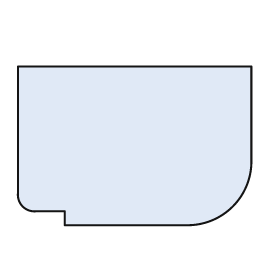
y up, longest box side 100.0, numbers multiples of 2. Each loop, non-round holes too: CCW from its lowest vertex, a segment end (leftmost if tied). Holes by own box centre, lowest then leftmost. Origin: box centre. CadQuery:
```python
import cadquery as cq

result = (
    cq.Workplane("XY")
    .moveTo(-30.0, -34.0)
    .lineTo(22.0, -34.0)
    .threePointArc((42.0, -26.0), (50.0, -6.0))
    .lineTo(50.0, 34.0)
    .lineTo(-50.0, 34.0)
    .lineTo(-50.0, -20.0)
    .threePointArc((-48.0, -26.0), (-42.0, -28.0))
    .lineTo(-30.0, -28.0)
    .close()
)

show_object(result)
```